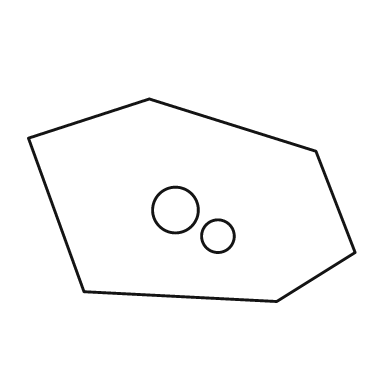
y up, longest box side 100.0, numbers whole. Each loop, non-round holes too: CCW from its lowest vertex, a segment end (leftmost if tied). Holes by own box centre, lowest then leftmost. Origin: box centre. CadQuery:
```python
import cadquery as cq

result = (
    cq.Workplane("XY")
    .moveTo(26.0, -31.0)
    .lineTo(50.0, -16.0)
    .lineTo(38.0, 15.0)
    .lineTo(-13.0, 31.0)
    .lineTo(-50.0, 19.0)
    .lineTo(-33.0, -28.0)
    .close()
    .moveTo(8.0, -11.0)
    .circle(5.0)
    .moveTo(-5.0, -3.0)
    .circle(7.0)
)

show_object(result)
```